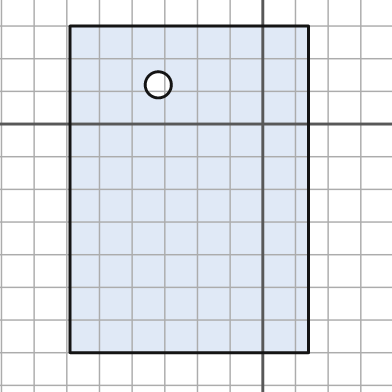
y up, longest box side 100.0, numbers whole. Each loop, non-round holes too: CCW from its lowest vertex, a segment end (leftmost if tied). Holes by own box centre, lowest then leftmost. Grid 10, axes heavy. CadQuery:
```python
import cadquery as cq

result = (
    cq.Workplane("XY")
    .moveTo(-59.0, -70.0)
    .lineTo(14.0, -70.0)
    .lineTo(14.0, 30.0)
    .lineTo(-59.0, 30.0)
    .close()
    .moveTo(-32.0, 12.0)
    .circle(4.0)
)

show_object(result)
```